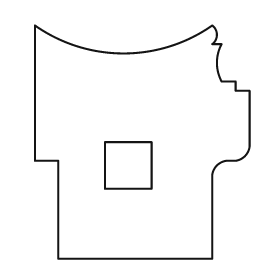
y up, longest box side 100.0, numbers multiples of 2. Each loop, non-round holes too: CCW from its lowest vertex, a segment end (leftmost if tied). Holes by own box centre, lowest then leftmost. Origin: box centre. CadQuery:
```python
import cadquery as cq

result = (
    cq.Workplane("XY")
    .moveTo(-36.0, -50.0)
    .lineTo(30.0, -50.0)
    .lineTo(30.0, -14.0)
    .threePointArc((32.0, -10.0), (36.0, -8.0))
    .lineTo(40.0, -8.0)
    .threePointArc((44.0, -6.0), (46.0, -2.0))
    .lineTo(46.0, 22.0)
    .lineTo(40.0, 22.0)
    .lineTo(40.0, 26.0)
    .lineTo(34.0, 26.0)
    .threePointArc((32.0, 34.0), (34.0, 42.0))
    .lineTo(30.0, 42.0)
    .threePointArc((32.0, 46.0), (30.0, 50.0))
    .threePointArc((-8.0, 38.0), (-46.0, 50.0))
    .lineTo(-46.0, -8.0)
    .lineTo(-36.0, -8.0)
    .close()
    .moveTo(-16.0, -20.0)
    .lineTo(4.0, -20.0)
    .lineTo(4.0, 0.0)
    .lineTo(-16.0, 0.0)
    .close()
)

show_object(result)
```